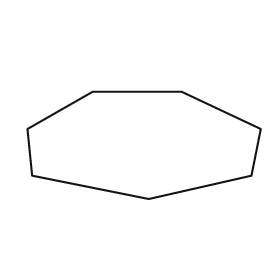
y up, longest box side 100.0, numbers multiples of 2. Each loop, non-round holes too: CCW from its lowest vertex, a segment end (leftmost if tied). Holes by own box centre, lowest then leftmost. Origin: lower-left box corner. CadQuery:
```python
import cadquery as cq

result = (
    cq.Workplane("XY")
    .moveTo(52.0, 0.0)
    .lineTo(96.0, 10.0)
    .lineTo(100.0, 30.0)
    .lineTo(66.0, 46.0)
    .lineTo(28.0, 46.0)
    .lineTo(0.0, 30.0)
    .lineTo(2.0, 10.0)
    .close()
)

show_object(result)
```